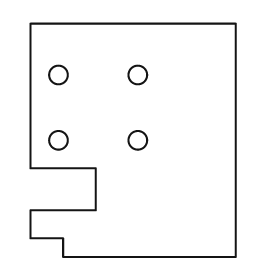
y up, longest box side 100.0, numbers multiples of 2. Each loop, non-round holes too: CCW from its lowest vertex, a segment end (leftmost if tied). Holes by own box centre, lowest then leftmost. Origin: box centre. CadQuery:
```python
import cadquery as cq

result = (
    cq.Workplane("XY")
    .moveTo(-30.0, -50.0)
    .lineTo(44.0, -50.0)
    .lineTo(44.0, 50.0)
    .lineTo(-44.0, 50.0)
    .lineTo(-44.0, -12.0)
    .lineTo(-16.0, -12.0)
    .lineTo(-16.0, -30.0)
    .lineTo(-44.0, -30.0)
    .lineTo(-44.0, -42.0)
    .lineTo(-30.0, -42.0)
    .close()
    .moveTo(-32.0, 0.0)
    .circle(4.0)
    .moveTo(2.0, 0.0)
    .circle(4.0)
    .moveTo(-32.0, 28.0)
    .circle(4.0)
    .moveTo(2.0, 28.0)
    .circle(4.0)
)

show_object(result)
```